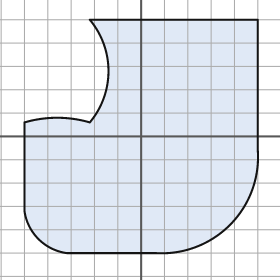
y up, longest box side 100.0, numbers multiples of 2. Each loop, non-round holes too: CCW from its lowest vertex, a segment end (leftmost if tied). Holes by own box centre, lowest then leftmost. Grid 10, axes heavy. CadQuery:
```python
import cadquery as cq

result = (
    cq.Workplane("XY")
    .moveTo(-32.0, -50.0)
    .lineTo(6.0, -50.0)
    .threePointArc((38.0, -38.0), (50.0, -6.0))
    .lineTo(50.0, 50.0)
    .lineTo(-22.0, 50.0)
    .threePointArc((-14.0, 28.0), (-22.0, 6.0))
    .threePointArc((-36.0, 8.0), (-50.0, 6.0))
    .lineTo(-50.0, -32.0)
    .threePointArc((-44.0, -44.0), (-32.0, -50.0))
    .close()
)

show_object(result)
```